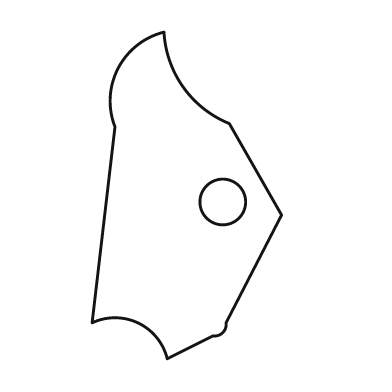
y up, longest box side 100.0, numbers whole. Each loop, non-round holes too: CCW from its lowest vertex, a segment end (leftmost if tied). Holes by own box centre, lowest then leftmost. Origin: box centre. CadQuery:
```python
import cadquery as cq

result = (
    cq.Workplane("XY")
    .moveTo(-6.0, -50.0)
    .lineTo(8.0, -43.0)
    .threePointArc((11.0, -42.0), (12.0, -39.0))
    .lineTo(29.0, -6.0)
    .lineTo(13.0, 22.0)
    .threePointArc((-1.0, 33.0), (-7.0, 50.0))
    .threePointArc((-21.0, 39.0), (-22.0, 21.0))
    .lineTo(-29.0, -39.0)
    .threePointArc((-15.0, -39.0), (-6.0, -50.0))
    .close()
    .moveTo(11.0, -2.0)
    .circle(7.0)
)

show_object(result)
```